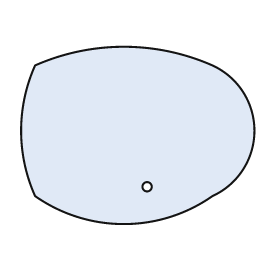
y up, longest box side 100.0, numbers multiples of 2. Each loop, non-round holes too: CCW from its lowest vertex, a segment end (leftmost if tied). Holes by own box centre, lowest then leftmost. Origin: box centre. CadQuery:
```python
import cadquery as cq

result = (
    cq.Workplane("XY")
    .moveTo(-44.0, -26.0)
    .threePointArc((-6.0, -38.0), (32.0, -26.0))
    .threePointArc((50.0, 2.0), (32.0, 30.0))
    .threePointArc((-6.0, 38.0), (-44.0, 30.0))
    .threePointArc((-50.0, 2.0), (-44.0, -26.0))
    .close()
    .moveTo(4.0, -22.0)
    .circle(2.0)
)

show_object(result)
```